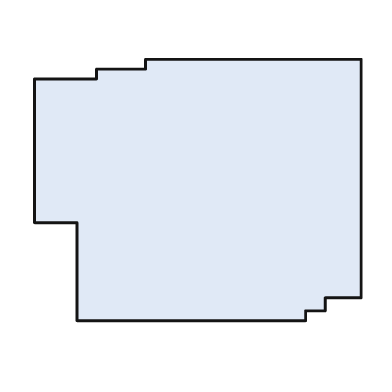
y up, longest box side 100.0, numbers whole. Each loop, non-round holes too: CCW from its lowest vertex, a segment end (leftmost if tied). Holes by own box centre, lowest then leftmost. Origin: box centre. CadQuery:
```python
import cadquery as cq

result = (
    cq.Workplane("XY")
    .moveTo(-37.0, -40.0)
    .lineTo(33.0, -40.0)
    .lineTo(33.0, -37.0)
    .lineTo(39.0, -37.0)
    .lineTo(39.0, -33.0)
    .lineTo(50.0, -33.0)
    .lineTo(50.0, 40.0)
    .lineTo(-16.0, 40.0)
    .lineTo(-16.0, 37.0)
    .lineTo(-31.0, 37.0)
    .lineTo(-31.0, 34.0)
    .lineTo(-50.0, 34.0)
    .lineTo(-50.0, -10.0)
    .lineTo(-37.0, -10.0)
    .close()
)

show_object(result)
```